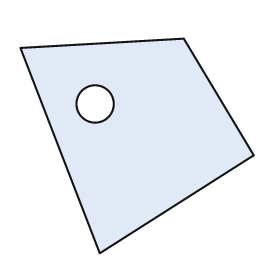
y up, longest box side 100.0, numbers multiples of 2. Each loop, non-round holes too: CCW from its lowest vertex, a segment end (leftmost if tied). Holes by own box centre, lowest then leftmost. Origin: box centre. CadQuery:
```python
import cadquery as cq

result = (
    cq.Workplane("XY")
    .moveTo(-16.0, -46.0)
    .lineTo(50.0, -4.0)
    .lineTo(20.0, 46.0)
    .lineTo(-50.0, 42.0)
    .close()
    .moveTo(-18.0, 18.0)
    .circle(8.0)
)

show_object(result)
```